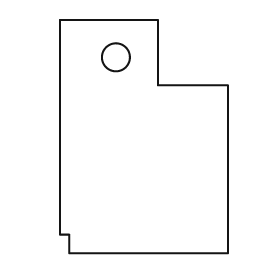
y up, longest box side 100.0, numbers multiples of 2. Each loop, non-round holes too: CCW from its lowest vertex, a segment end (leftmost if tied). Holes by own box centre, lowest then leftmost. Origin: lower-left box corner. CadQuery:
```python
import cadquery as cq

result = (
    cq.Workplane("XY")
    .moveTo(4.0, 0.0)
    .lineTo(72.0, 0.0)
    .lineTo(72.0, 72.0)
    .lineTo(42.0, 72.0)
    .lineTo(42.0, 100.0)
    .lineTo(0.0, 100.0)
    .lineTo(0.0, 8.0)
    .lineTo(4.0, 8.0)
    .close()
    .moveTo(24.0, 84.0)
    .circle(6.0)
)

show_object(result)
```